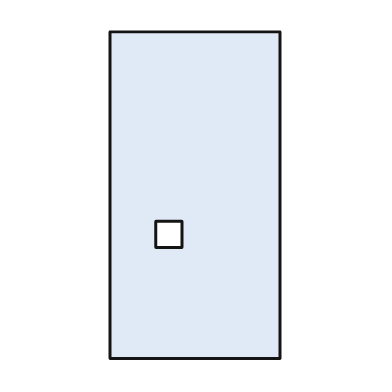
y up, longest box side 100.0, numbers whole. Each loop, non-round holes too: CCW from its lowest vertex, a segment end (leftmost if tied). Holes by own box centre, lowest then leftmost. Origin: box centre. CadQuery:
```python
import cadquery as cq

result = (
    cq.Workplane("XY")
    .moveTo(-26.0, -50.0)
    .lineTo(26.0, -50.0)
    .lineTo(26.0, 50.0)
    .lineTo(-26.0, 50.0)
    .close()
    .moveTo(-12.0, -16.0)
    .lineTo(-4.0, -16.0)
    .lineTo(-4.0, -8.0)
    .lineTo(-12.0, -8.0)
    .close()
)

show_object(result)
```